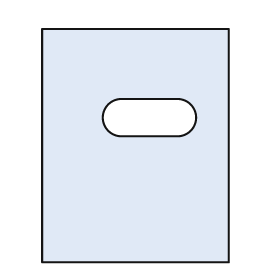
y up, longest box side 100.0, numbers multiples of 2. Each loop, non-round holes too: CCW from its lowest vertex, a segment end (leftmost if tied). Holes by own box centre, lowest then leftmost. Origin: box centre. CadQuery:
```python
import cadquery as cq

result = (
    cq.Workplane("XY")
    .moveTo(-40.0, -50.0)
    .lineTo(40.0, -50.0)
    .lineTo(40.0, 50.0)
    .lineTo(-40.0, 50.0)
    .close()
    .moveTo(-6.0, 4.0)
    .lineTo(18.0, 4.0)
    .threePointArc((26.0, 12.0), (18.0, 20.0))
    .lineTo(-6.0, 20.0)
    .threePointArc((-14.0, 12.0), (-6.0, 4.0))
    .close()
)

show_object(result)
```